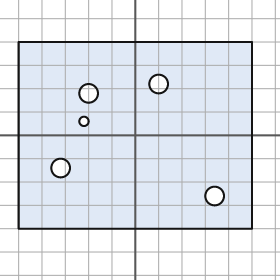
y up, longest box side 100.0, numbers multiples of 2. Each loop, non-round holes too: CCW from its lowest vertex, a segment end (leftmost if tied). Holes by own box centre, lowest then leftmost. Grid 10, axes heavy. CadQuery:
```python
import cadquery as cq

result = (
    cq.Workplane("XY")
    .moveTo(-50.0, -40.0)
    .lineTo(50.0, -40.0)
    .lineTo(50.0, 40.0)
    .lineTo(-50.0, 40.0)
    .close()
    .moveTo(34.0, -26.0)
    .circle(4.0)
    .moveTo(-32.0, -14.0)
    .circle(4.0)
    .moveTo(-22.0, 6.0)
    .circle(2.0)
    .moveTo(-20.0, 18.0)
    .circle(4.0)
    .moveTo(10.0, 22.0)
    .circle(4.0)
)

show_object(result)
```